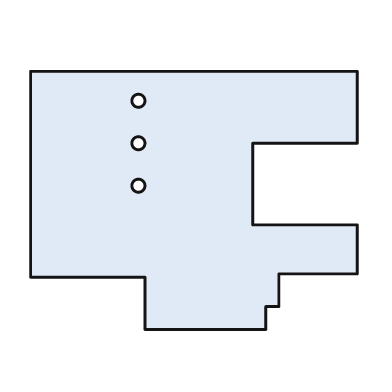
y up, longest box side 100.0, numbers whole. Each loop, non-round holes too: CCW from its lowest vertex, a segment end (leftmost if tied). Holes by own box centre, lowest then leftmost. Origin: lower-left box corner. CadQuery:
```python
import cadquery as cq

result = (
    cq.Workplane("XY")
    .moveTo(35.0, 0.0)
    .lineTo(72.0, 0.0)
    .lineTo(72.0, 7.0)
    .lineTo(76.0, 7.0)
    .lineTo(76.0, 17.0)
    .lineTo(100.0, 17.0)
    .lineTo(100.0, 32.0)
    .lineTo(68.0, 32.0)
    .lineTo(68.0, 57.0)
    .lineTo(100.0, 57.0)
    .lineTo(100.0, 79.0)
    .lineTo(0.0, 79.0)
    .lineTo(0.0, 16.0)
    .lineTo(35.0, 16.0)
    .close()
    .moveTo(33.0, 44.0)
    .circle(2.0)
    .moveTo(33.0, 57.0)
    .circle(2.0)
    .moveTo(33.0, 70.0)
    .circle(2.0)
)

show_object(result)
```